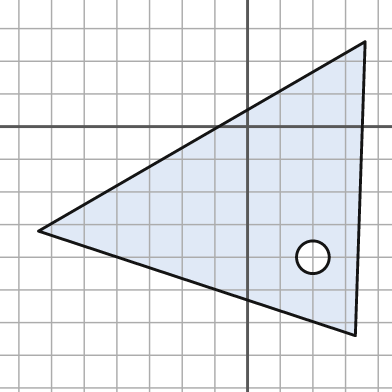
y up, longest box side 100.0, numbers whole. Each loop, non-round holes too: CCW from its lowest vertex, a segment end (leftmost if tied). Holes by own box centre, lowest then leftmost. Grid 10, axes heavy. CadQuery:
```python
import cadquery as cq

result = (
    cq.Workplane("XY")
    .moveTo(33.0, -64.0)
    .lineTo(36.0, 26.0)
    .lineTo(-64.0, -32.0)
    .close()
    .moveTo(20.0, -40.0)
    .circle(5.0)
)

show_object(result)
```